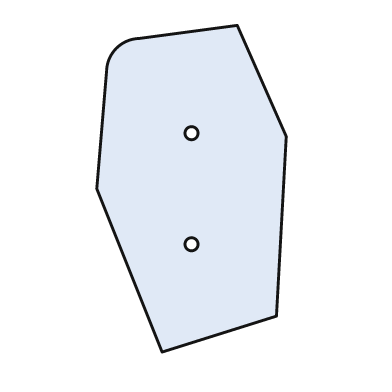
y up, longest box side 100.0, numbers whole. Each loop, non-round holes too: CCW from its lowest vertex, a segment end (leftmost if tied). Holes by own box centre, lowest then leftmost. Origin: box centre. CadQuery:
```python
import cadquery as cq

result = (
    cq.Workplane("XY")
    .moveTo(-9.0, -50.0)
    .lineTo(26.0, -39.0)
    .lineTo(29.0, 16.0)
    .lineTo(14.0, 50.0)
    .lineTo(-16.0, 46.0)
    .threePointArc((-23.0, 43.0), (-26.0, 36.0))
    .lineTo(-29.0, 0.0)
    .close()
    .moveTo(0.0, -17.0)
    .circle(2.0)
    .moveTo(0.0, 17.0)
    .circle(2.0)
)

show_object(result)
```